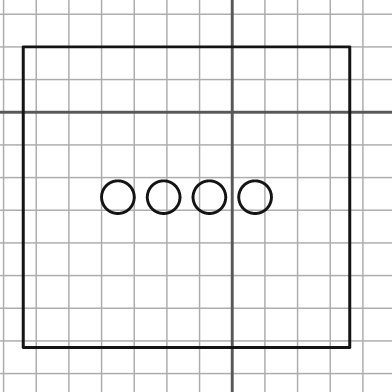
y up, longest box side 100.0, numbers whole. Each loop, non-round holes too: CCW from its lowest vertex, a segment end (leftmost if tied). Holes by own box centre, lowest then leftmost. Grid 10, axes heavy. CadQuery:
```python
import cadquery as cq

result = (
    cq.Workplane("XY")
    .moveTo(-64.0, -72.0)
    .lineTo(36.0, -72.0)
    .lineTo(36.0, 20.0)
    .lineTo(-64.0, 20.0)
    .close()
    .moveTo(-35.0, -26.0)
    .circle(5.0)
    .moveTo(-21.0, -26.0)
    .circle(5.0)
    .moveTo(-7.0, -26.0)
    .circle(5.0)
    .moveTo(7.0, -26.0)
    .circle(5.0)
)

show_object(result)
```